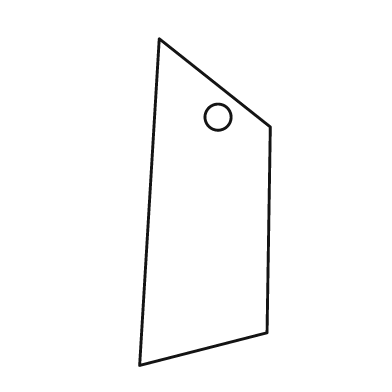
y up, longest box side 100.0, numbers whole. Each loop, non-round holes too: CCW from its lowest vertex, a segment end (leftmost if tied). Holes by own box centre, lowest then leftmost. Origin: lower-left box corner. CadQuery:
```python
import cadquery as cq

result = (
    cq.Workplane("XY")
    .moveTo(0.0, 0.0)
    .lineTo(39.0, 10.0)
    .lineTo(40.0, 73.0)
    .lineTo(6.0, 100.0)
    .close()
    .moveTo(24.0, 76.0)
    .circle(4.0)
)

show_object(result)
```